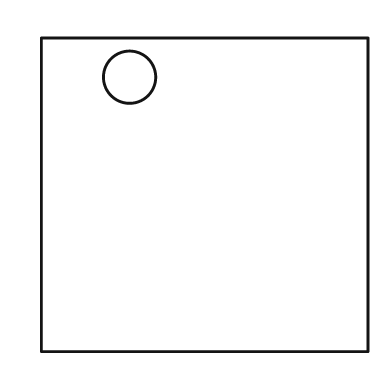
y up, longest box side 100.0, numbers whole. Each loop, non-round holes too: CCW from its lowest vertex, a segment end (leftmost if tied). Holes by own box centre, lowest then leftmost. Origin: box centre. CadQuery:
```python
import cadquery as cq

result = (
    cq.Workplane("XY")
    .moveTo(-50.0, -48.0)
    .lineTo(50.0, -48.0)
    .lineTo(50.0, 48.0)
    .lineTo(-50.0, 48.0)
    .close()
    .moveTo(-23.0, 36.0)
    .circle(8.0)
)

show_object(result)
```